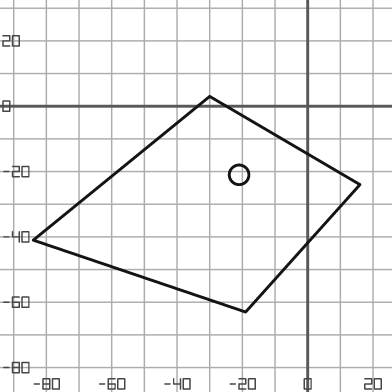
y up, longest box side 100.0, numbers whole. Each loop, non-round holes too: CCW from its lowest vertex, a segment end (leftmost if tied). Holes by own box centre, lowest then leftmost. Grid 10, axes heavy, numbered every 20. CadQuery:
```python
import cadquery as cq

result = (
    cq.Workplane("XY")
    .moveTo(-19.0, -63.0)
    .lineTo(16.0, -24.0)
    .lineTo(-30.0, 3.0)
    .lineTo(-84.0, -41.0)
    .close()
    .moveTo(-21.0, -21.0)
    .circle(3.0)
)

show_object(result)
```